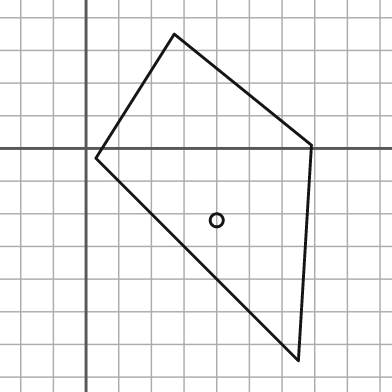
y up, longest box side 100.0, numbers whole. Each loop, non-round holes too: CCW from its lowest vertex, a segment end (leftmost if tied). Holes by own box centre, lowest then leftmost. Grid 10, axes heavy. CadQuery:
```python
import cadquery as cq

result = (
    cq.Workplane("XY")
    .moveTo(65.0, -65.0)
    .lineTo(69.0, 1.0)
    .lineTo(27.0, 35.0)
    .lineTo(3.0, -3.0)
    .close()
    .moveTo(40.0, -22.0)
    .circle(2.0)
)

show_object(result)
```